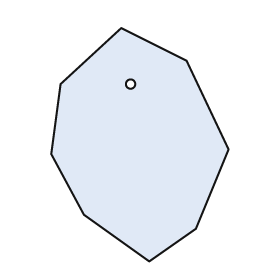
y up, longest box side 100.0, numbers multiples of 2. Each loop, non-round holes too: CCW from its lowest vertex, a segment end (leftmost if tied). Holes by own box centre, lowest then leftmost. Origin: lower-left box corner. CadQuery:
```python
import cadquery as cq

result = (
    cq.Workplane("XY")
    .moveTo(42.0, 0.0)
    .lineTo(62.0, 14.0)
    .lineTo(76.0, 48.0)
    .lineTo(58.0, 86.0)
    .lineTo(30.0, 100.0)
    .lineTo(4.0, 76.0)
    .lineTo(0.0, 46.0)
    .lineTo(14.0, 20.0)
    .close()
    .moveTo(34.0, 76.0)
    .circle(2.0)
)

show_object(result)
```